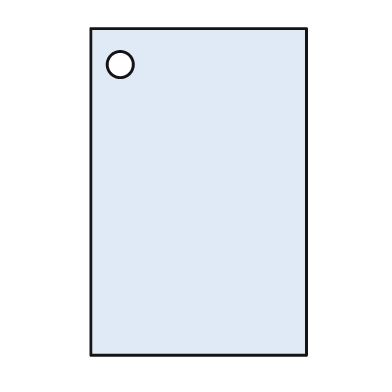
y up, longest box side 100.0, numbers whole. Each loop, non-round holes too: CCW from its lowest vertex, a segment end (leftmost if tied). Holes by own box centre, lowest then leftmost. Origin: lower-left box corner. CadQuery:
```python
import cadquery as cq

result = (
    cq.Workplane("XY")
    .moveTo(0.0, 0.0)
    .lineTo(66.0, 0.0)
    .lineTo(66.0, 100.0)
    .lineTo(0.0, 100.0)
    .close()
    .moveTo(9.0, 89.0)
    .circle(4.0)
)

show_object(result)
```